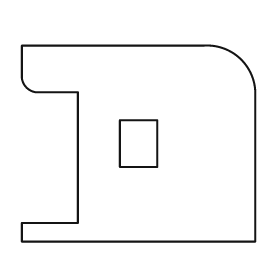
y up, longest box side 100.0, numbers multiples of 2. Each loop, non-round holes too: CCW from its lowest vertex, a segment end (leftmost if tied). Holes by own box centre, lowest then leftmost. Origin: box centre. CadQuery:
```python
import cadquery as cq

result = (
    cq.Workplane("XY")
    .moveTo(-50.0, -42.0)
    .lineTo(50.0, -42.0)
    .lineTo(50.0, 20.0)
    .threePointArc((44.0, 36.0), (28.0, 42.0))
    .lineTo(-50.0, 42.0)
    .lineTo(-50.0, 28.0)
    .threePointArc((-48.0, 24.0), (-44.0, 22.0))
    .lineTo(-26.0, 22.0)
    .lineTo(-26.0, -34.0)
    .lineTo(-50.0, -34.0)
    .close()
    .moveTo(-8.0, -10.0)
    .lineTo(8.0, -10.0)
    .lineTo(8.0, 10.0)
    .lineTo(-8.0, 10.0)
    .close()
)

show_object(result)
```